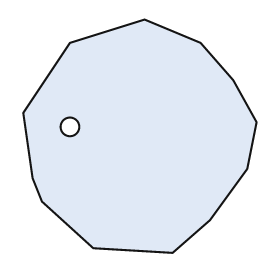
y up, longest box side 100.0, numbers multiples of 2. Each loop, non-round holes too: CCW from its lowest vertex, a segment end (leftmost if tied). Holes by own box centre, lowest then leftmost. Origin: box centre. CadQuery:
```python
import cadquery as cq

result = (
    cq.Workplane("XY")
    .moveTo(14.0, -50.0)
    .lineTo(30.0, -36.0)
    .lineTo(46.0, -14.0)
    .lineTo(50.0, 6.0)
    .lineTo(40.0, 24.0)
    .lineTo(26.0, 40.0)
    .lineTo(2.0, 50.0)
    .lineTo(-30.0, 40.0)
    .lineTo(-50.0, 10.0)
    .lineTo(-46.0, -18.0)
    .lineTo(-42.0, -28.0)
    .lineTo(-20.0, -48.0)
    .close()
    .moveTo(-30.0, 4.0)
    .circle(4.0)
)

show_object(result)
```